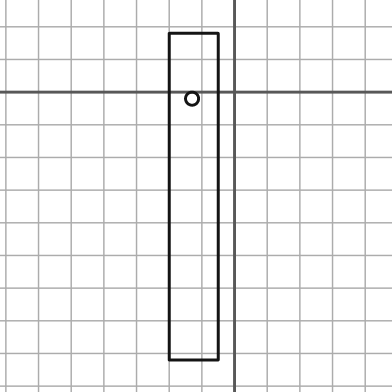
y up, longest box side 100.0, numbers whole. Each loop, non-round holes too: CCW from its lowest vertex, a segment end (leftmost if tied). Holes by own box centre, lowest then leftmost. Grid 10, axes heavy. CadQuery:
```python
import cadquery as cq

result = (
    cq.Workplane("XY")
    .moveTo(-20.0, -82.0)
    .lineTo(-5.0, -82.0)
    .lineTo(-5.0, 18.0)
    .lineTo(-20.0, 18.0)
    .close()
    .moveTo(-13.0, -2.0)
    .circle(2.0)
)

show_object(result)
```